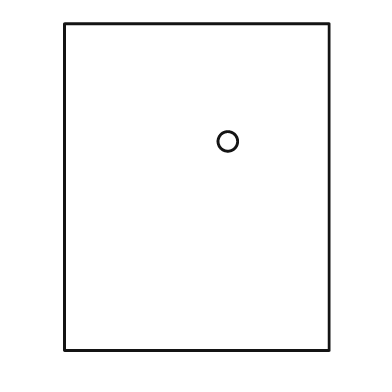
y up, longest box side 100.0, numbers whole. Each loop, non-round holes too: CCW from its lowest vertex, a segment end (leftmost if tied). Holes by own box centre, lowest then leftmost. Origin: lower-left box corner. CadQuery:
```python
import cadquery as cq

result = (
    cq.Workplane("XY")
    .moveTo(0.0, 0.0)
    .lineTo(81.0, 0.0)
    .lineTo(81.0, 100.0)
    .lineTo(0.0, 100.0)
    .close()
    .moveTo(50.0, 64.0)
    .circle(3.0)
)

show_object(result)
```